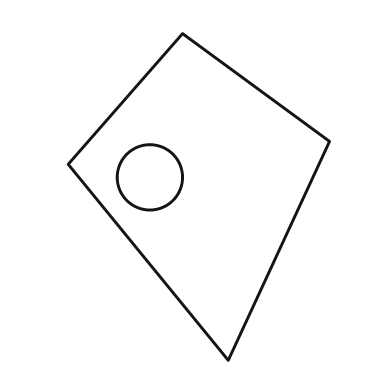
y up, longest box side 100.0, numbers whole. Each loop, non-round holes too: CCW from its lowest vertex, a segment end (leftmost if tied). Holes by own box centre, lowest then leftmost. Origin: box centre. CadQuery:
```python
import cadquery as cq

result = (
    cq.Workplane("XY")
    .moveTo(9.0, -50.0)
    .lineTo(40.0, 17.0)
    .lineTo(-5.0, 50.0)
    .lineTo(-40.0, 10.0)
    .close()
    .moveTo(-15.0, 6.0)
    .circle(10.0)
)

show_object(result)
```